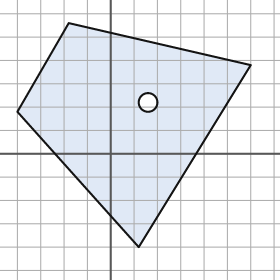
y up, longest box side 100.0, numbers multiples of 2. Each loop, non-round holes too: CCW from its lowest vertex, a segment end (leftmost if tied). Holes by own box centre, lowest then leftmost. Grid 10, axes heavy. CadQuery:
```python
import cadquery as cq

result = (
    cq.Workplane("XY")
    .moveTo(12.0, -40.0)
    .lineTo(60.0, 38.0)
    .lineTo(-18.0, 56.0)
    .lineTo(-40.0, 18.0)
    .close()
    .moveTo(16.0, 22.0)
    .circle(4.0)
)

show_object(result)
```